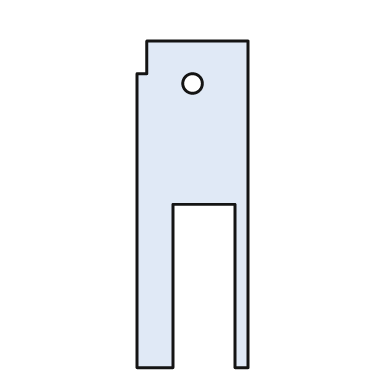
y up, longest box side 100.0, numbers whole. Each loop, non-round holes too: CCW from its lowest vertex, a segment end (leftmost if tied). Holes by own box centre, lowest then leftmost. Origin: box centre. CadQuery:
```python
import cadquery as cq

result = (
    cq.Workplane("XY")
    .moveTo(-17.0, -50.0)
    .lineTo(-6.0, -50.0)
    .lineTo(-6.0, 0.0)
    .lineTo(13.0, 0.0)
    .lineTo(13.0, -50.0)
    .lineTo(17.0, -50.0)
    .lineTo(17.0, 50.0)
    .lineTo(-14.0, 50.0)
    .lineTo(-14.0, 40.0)
    .lineTo(-17.0, 40.0)
    .close()
    .moveTo(0.0, 37.0)
    .circle(3.0)
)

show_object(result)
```